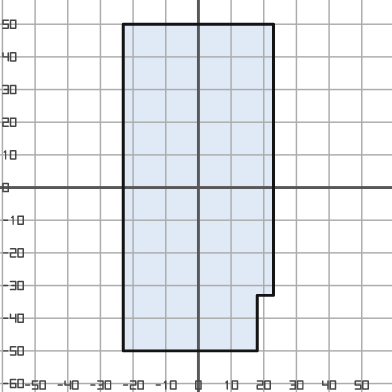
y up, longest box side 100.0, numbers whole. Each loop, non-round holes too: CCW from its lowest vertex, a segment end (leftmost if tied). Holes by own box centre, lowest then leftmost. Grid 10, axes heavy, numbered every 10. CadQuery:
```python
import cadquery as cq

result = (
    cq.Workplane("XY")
    .moveTo(-23.0, -50.0)
    .lineTo(18.0, -50.0)
    .lineTo(18.0, -33.0)
    .lineTo(23.0, -33.0)
    .lineTo(23.0, 50.0)
    .lineTo(-23.0, 50.0)
    .close()
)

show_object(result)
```